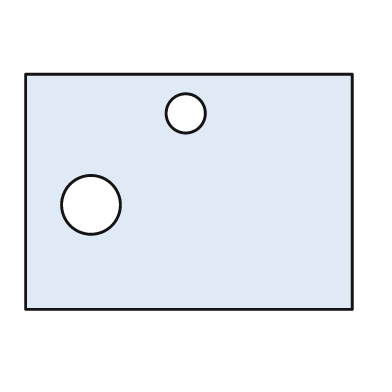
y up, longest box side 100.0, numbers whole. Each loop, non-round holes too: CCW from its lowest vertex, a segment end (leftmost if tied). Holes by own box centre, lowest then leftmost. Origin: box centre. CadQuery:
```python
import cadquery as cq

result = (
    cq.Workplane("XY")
    .moveTo(-50.0, -36.0)
    .lineTo(50.0, -36.0)
    .lineTo(50.0, 36.0)
    .lineTo(-50.0, 36.0)
    .close()
    .moveTo(-30.0, -4.0)
    .circle(9.0)
    .moveTo(-1.0, 24.0)
    .circle(6.0)
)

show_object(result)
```